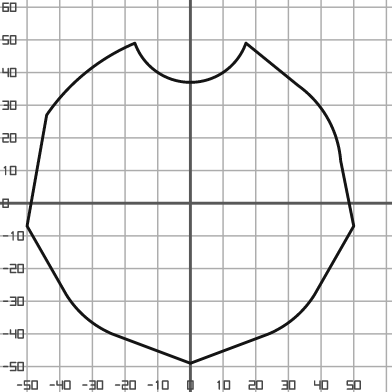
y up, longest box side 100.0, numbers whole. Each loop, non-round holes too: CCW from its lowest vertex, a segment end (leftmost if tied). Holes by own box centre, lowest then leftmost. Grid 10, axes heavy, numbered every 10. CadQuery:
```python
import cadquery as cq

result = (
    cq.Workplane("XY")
    .moveTo(0.0, -49.0)
    .lineTo(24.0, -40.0)
    .threePointArc((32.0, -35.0), (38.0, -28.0))
    .lineTo(50.0, -7.0)
    .lineTo(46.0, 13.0)
    .threePointArc((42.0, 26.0), (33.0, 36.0))
    .lineTo(17.0, 49.0)
    .threePointArc((0.0, 37.0), (-17.0, 49.0))
    .threePointArc((-32.0, 40.0), (-44.0, 27.0))
    .lineTo(-50.0, -7.0)
    .lineTo(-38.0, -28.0)
    .threePointArc((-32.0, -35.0), (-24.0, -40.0))
    .close()
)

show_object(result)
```